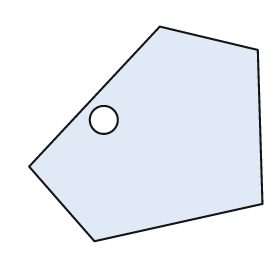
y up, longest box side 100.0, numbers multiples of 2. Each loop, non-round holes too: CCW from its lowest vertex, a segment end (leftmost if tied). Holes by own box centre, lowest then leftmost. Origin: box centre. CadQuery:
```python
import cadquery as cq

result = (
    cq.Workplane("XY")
    .moveTo(-22.0, -46.0)
    .lineTo(50.0, -30.0)
    .lineTo(48.0, 36.0)
    .lineTo(6.0, 46.0)
    .lineTo(-50.0, -14.0)
    .close()
    .moveTo(-18.0, 6.0)
    .circle(6.0)
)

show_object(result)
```